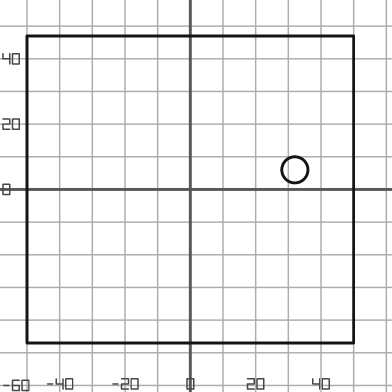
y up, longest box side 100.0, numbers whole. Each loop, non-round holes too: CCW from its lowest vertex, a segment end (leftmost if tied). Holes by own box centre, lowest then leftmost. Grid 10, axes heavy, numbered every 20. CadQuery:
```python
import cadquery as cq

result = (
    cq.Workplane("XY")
    .moveTo(-50.0, -47.0)
    .lineTo(50.0, -47.0)
    .lineTo(50.0, 47.0)
    .lineTo(-50.0, 47.0)
    .close()
    .moveTo(32.0, 6.0)
    .circle(4.0)
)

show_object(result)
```